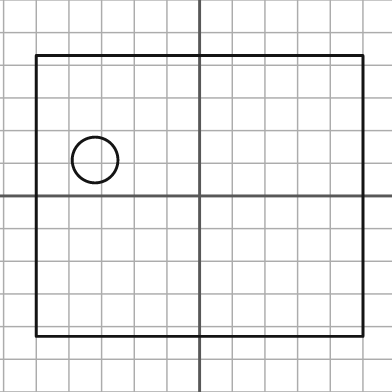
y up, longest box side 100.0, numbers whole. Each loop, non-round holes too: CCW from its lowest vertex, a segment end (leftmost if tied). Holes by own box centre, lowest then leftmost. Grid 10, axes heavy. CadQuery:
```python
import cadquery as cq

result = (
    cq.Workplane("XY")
    .moveTo(-50.0, -43.0)
    .lineTo(50.0, -43.0)
    .lineTo(50.0, 43.0)
    .lineTo(-50.0, 43.0)
    .close()
    .moveTo(-32.0, 11.0)
    .circle(7.0)
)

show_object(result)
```